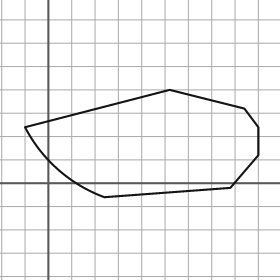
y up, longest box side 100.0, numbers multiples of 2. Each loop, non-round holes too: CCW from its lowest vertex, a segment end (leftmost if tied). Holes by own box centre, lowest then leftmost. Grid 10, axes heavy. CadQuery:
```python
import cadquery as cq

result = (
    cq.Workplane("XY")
    .moveTo(24.0, -6.0)
    .lineTo(78.0, -2.0)
    .lineTo(90.0, 12.0)
    .lineTo(90.0, 24.0)
    .lineTo(84.0, 32.0)
    .lineTo(52.0, 40.0)
    .lineTo(-10.0, 24.0)
    .threePointArc((4.0, 6.0), (24.0, -6.0))
    .close()
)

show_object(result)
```